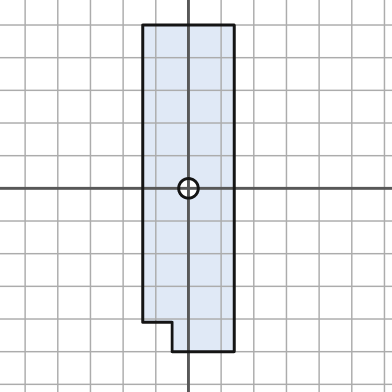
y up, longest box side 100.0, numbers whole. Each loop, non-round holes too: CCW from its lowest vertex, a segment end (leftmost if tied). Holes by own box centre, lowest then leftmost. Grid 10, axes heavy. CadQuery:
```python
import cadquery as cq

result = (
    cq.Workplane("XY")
    .moveTo(-5.0, -50.0)
    .lineTo(14.0, -50.0)
    .lineTo(14.0, 50.0)
    .lineTo(-14.0, 50.0)
    .lineTo(-14.0, -41.0)
    .lineTo(-5.0, -41.0)
    .close()
    .moveTo(0.0, 0.0)
    .circle(3.0)
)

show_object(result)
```